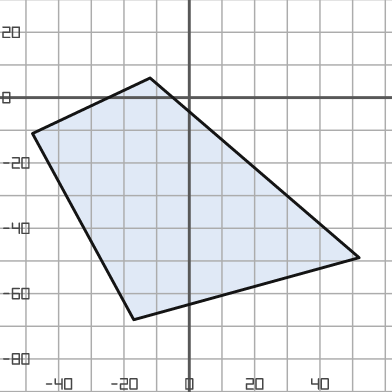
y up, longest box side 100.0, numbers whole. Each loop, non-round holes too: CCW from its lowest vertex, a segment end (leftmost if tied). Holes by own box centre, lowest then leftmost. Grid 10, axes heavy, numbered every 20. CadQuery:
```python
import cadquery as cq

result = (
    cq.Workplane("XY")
    .moveTo(-17.0, -68.0)
    .lineTo(52.0, -49.0)
    .lineTo(-12.0, 6.0)
    .lineTo(-48.0, -11.0)
    .close()
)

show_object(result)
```